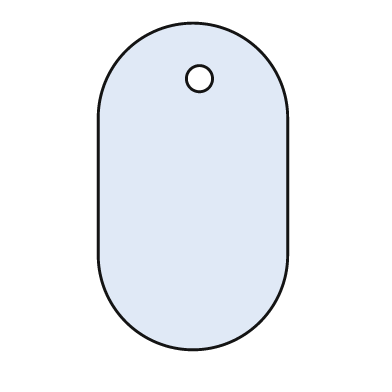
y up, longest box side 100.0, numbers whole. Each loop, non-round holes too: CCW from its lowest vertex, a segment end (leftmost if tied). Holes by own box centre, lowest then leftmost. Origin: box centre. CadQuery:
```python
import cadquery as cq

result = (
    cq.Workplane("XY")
    .moveTo(-29.0, -21.0)
    .threePointArc((0.0, -50.0), (29.0, -21.0))
    .lineTo(29.0, 21.0)
    .threePointArc((0.0, 50.0), (-29.0, 21.0))
    .close()
    .moveTo(2.0, 33.0)
    .circle(4.0)
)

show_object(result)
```